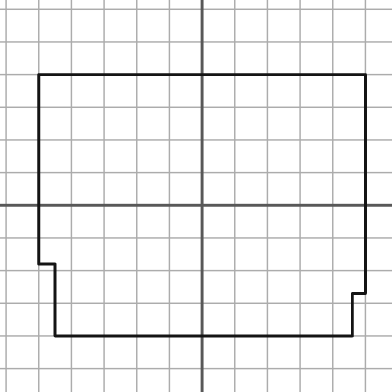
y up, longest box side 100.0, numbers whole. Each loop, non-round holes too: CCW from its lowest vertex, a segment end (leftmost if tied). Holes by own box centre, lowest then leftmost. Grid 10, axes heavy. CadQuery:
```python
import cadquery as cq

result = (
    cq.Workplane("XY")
    .moveTo(-45.0, -40.0)
    .lineTo(46.0, -40.0)
    .lineTo(46.0, -27.0)
    .lineTo(50.0, -27.0)
    .lineTo(50.0, 40.0)
    .lineTo(-50.0, 40.0)
    .lineTo(-50.0, -18.0)
    .lineTo(-45.0, -18.0)
    .close()
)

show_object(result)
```